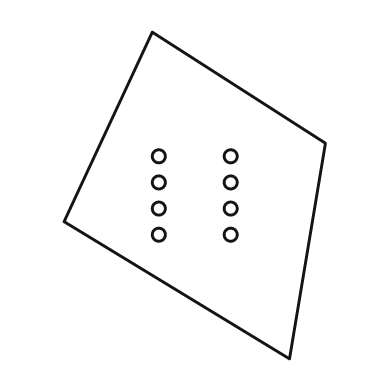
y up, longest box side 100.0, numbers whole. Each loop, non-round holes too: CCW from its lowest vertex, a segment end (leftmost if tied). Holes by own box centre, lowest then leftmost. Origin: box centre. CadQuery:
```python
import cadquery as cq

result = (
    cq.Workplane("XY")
    .moveTo(29.0, -50.0)
    .lineTo(40.0, 16.0)
    .lineTo(-13.0, 50.0)
    .lineTo(-40.0, -8.0)
    .close()
    .moveTo(-11.0, -12.0)
    .circle(2.0)
    .moveTo(11.0, -12.0)
    .circle(2.0)
    .moveTo(-11.0, -4.0)
    .circle(2.0)
    .moveTo(11.0, -4.0)
    .circle(2.0)
    .moveTo(-11.0, 4.0)
    .circle(2.0)
    .moveTo(11.0, 4.0)
    .circle(2.0)
    .moveTo(-11.0, 12.0)
    .circle(2.0)
    .moveTo(11.0, 12.0)
    .circle(2.0)
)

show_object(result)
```